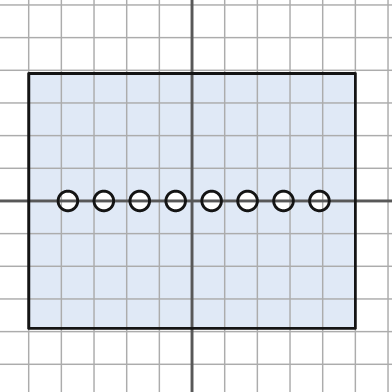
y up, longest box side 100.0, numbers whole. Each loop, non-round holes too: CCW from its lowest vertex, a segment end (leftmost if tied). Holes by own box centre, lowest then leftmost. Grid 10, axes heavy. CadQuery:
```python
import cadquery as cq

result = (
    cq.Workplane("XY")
    .moveTo(-50.0, -39.0)
    .lineTo(50.0, -39.0)
    .lineTo(50.0, 39.0)
    .lineTo(-50.0, 39.0)
    .close()
    .moveTo(-38.0, 0.0)
    .circle(3.0)
    .moveTo(-27.0, 0.0)
    .circle(3.0)
    .moveTo(-16.0, 0.0)
    .circle(3.0)
    .moveTo(-5.0, 0.0)
    .circle(3.0)
    .moveTo(6.0, 0.0)
    .circle(3.0)
    .moveTo(17.0, 0.0)
    .circle(3.0)
    .moveTo(28.0, 0.0)
    .circle(3.0)
    .moveTo(39.0, 0.0)
    .circle(3.0)
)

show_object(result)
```